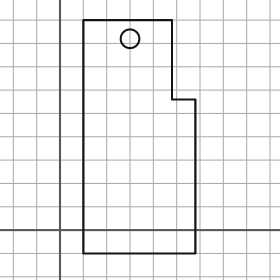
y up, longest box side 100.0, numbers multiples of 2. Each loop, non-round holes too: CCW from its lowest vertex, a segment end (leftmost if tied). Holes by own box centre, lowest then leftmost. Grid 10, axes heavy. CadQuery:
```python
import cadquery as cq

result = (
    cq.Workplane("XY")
    .moveTo(10.0, -10.0)
    .lineTo(58.0, -10.0)
    .lineTo(58.0, 56.0)
    .lineTo(48.0, 56.0)
    .lineTo(48.0, 90.0)
    .lineTo(10.0, 90.0)
    .close()
    .moveTo(30.0, 82.0)
    .circle(4.0)
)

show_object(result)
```